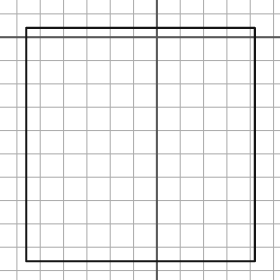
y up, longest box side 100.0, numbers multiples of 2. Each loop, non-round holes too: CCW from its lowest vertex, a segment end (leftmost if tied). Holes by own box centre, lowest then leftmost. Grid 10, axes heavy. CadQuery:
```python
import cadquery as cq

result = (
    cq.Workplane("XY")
    .moveTo(-56.0, -96.0)
    .lineTo(42.0, -96.0)
    .lineTo(42.0, 4.0)
    .lineTo(-56.0, 4.0)
    .close()
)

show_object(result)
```